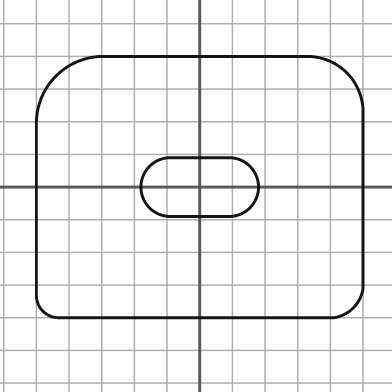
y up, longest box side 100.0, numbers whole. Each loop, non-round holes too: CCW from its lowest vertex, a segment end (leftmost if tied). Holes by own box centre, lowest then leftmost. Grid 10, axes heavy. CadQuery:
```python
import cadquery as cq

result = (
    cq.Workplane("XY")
    .moveTo(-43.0, -40.0)
    .lineTo(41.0, -40.0)
    .threePointArc((47.0, -37.0), (50.0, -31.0))
    .lineTo(50.0, 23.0)
    .threePointArc((45.0, 35.0), (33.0, 40.0))
    .lineTo(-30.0, 40.0)
    .threePointArc((-44.0, 34.0), (-50.0, 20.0))
    .lineTo(-50.0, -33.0)
    .threePointArc((-48.0, -38.0), (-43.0, -40.0))
    .close()
    .moveTo(-9.0, -9.0)
    .lineTo(9.0, -9.0)
    .threePointArc((18.0, 0.0), (9.0, 9.0))
    .lineTo(-9.0, 9.0)
    .threePointArc((-18.0, 0.0), (-9.0, -9.0))
    .close()
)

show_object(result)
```